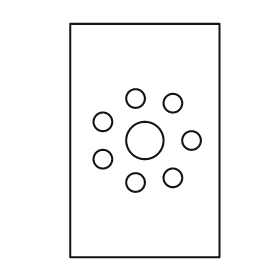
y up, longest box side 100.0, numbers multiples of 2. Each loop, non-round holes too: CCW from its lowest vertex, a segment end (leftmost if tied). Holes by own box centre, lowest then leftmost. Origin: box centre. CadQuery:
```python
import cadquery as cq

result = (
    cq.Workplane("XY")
    .moveTo(-32.0, -50.0)
    .lineTo(32.0, -50.0)
    .lineTo(32.0, 50.0)
    .lineTo(-32.0, 50.0)
    .close()
    .moveTo(-4.0, -18.0)
    .circle(4.0)
    .moveTo(12.0, -16.0)
    .circle(4.0)
    .moveTo(-18.0, -8.0)
    .circle(4.0)
    .moveTo(0.0, 0.0)
    .circle(8.0)
    .moveTo(20.0, 0.0)
    .circle(4.0)
    .moveTo(-18.0, 8.0)
    .circle(4.0)
    .moveTo(12.0, 16.0)
    .circle(4.0)
    .moveTo(-4.0, 18.0)
    .circle(4.0)
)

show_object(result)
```